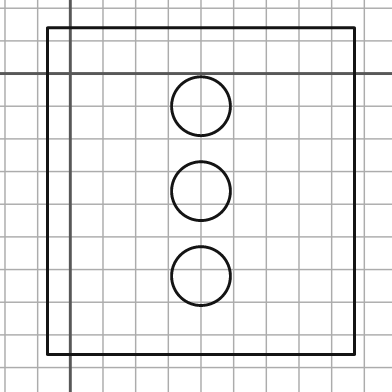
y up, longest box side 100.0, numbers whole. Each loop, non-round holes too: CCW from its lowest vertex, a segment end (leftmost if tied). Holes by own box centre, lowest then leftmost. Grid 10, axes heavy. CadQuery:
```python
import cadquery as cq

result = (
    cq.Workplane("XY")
    .moveTo(-7.0, -86.0)
    .lineTo(87.0, -86.0)
    .lineTo(87.0, 14.0)
    .lineTo(-7.0, 14.0)
    .close()
    .moveTo(40.0, -62.0)
    .circle(9.0)
    .moveTo(40.0, -36.0)
    .circle(9.0)
    .moveTo(40.0, -10.0)
    .circle(9.0)
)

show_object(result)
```